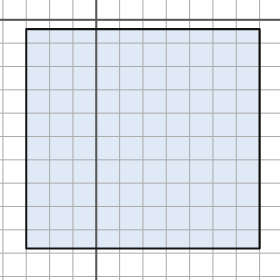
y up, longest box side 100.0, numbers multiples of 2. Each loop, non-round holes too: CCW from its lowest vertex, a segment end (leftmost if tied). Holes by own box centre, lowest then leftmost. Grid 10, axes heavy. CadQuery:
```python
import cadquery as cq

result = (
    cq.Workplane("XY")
    .moveTo(-30.0, -98.0)
    .lineTo(70.0, -98.0)
    .lineTo(70.0, -4.0)
    .lineTo(-30.0, -4.0)
    .close()
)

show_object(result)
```